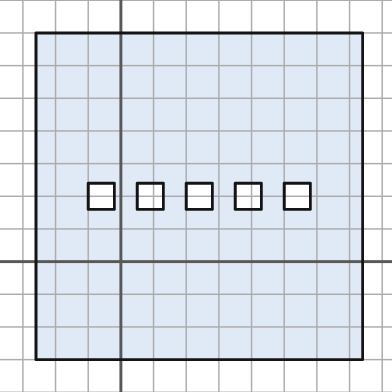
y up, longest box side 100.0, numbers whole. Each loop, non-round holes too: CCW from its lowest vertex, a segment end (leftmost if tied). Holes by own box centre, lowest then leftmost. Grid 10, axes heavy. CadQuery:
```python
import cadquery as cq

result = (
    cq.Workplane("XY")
    .moveTo(-26.0, -30.0)
    .lineTo(74.0, -30.0)
    .lineTo(74.0, 70.0)
    .lineTo(-26.0, 70.0)
    .close()
    .moveTo(-10.0, 16.0)
    .lineTo(-2.0, 16.0)
    .lineTo(-2.0, 24.0)
    .lineTo(-10.0, 24.0)
    .close()
    .moveTo(5.0, 16.0)
    .lineTo(13.0, 16.0)
    .lineTo(13.0, 24.0)
    .lineTo(5.0, 24.0)
    .close()
    .moveTo(20.0, 16.0)
    .lineTo(28.0, 16.0)
    .lineTo(28.0, 24.0)
    .lineTo(20.0, 24.0)
    .close()
    .moveTo(35.0, 16.0)
    .lineTo(43.0, 16.0)
    .lineTo(43.0, 24.0)
    .lineTo(35.0, 24.0)
    .close()
    .moveTo(50.0, 16.0)
    .lineTo(58.0, 16.0)
    .lineTo(58.0, 24.0)
    .lineTo(50.0, 24.0)
    .close()
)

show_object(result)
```